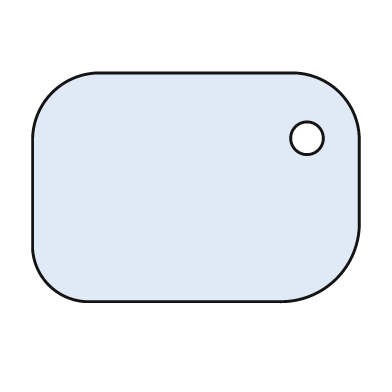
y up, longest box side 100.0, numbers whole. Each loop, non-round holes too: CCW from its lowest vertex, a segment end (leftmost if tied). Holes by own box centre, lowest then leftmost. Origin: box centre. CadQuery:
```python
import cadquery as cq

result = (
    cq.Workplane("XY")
    .moveTo(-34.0, -35.0)
    .lineTo(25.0, -35.0)
    .threePointArc((43.0, -28.0), (50.0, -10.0))
    .lineTo(50.0, 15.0)
    .threePointArc((44.0, 29.0), (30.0, 35.0))
    .lineTo(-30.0, 35.0)
    .threePointArc((-44.0, 29.0), (-50.0, 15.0))
    .lineTo(-50.0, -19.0)
    .threePointArc((-45.0, -30.0), (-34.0, -35.0))
    .close()
    .moveTo(34.0, 15.0)
    .circle(5.0)
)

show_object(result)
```